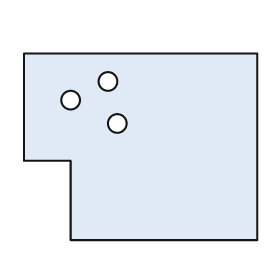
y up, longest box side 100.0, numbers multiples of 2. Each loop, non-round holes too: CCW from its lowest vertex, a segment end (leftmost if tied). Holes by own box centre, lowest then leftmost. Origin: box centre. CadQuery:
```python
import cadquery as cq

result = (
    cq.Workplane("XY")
    .moveTo(-30.0, -40.0)
    .lineTo(50.0, -40.0)
    .lineTo(50.0, 40.0)
    .lineTo(-50.0, 40.0)
    .lineTo(-50.0, -6.0)
    .lineTo(-30.0, -6.0)
    .close()
    .moveTo(-10.0, 10.0)
    .circle(4.0)
    .moveTo(-30.0, 20.0)
    .circle(4.0)
    .moveTo(-14.0, 28.0)
    .circle(4.0)
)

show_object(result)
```